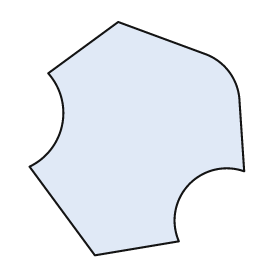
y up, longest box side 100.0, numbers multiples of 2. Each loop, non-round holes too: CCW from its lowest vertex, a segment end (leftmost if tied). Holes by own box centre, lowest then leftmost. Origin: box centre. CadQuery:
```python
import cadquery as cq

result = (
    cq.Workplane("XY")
    .moveTo(-18.0, -50.0)
    .lineTo(18.0, -44.0)
    .threePointArc((22.0, -20.0), (46.0, -14.0))
    .lineTo(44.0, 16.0)
    .threePointArc((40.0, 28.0), (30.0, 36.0))
    .lineTo(-8.0, 50.0)
    .lineTo(-38.0, 28.0)
    .threePointArc((-32.0, 6.0), (-46.0, -12.0))
    .close()
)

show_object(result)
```